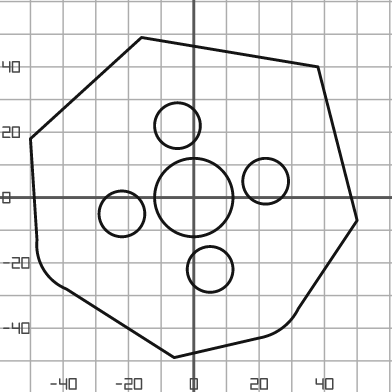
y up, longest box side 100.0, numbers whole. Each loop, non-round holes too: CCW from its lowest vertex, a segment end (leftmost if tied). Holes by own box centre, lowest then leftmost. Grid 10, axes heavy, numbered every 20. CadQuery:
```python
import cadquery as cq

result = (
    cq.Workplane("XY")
    .moveTo(-6.0, -49.0)
    .lineTo(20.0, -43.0)
    .threePointArc((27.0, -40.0), (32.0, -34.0))
    .lineTo(50.0, -7.0)
    .lineTo(38.0, 40.0)
    .lineTo(-16.0, 49.0)
    .lineTo(-50.0, 18.0)
    .lineTo(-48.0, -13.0)
    .threePointArc((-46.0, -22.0), (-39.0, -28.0))
    .close()
    .moveTo(5.0, -22.0)
    .circle(7.0)
    .moveTo(-22.0, -5.0)
    .circle(7.0)
    .moveTo(0.0, 0.0)
    .circle(12.0)
    .moveTo(22.0, 5.0)
    .circle(7.0)
    .moveTo(-5.0, 22.0)
    .circle(7.0)
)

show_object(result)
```